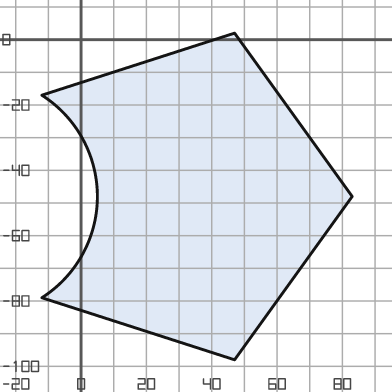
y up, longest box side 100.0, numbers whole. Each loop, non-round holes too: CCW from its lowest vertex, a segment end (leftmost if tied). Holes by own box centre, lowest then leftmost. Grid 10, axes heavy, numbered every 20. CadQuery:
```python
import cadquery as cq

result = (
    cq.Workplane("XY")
    .moveTo(47.0, -98.0)
    .lineTo(83.0, -48.0)
    .lineTo(47.0, 2.0)
    .lineTo(-12.0, -17.0)
    .threePointArc((5.0, -48.0), (-12.0, -79.0))
    .close()
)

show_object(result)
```